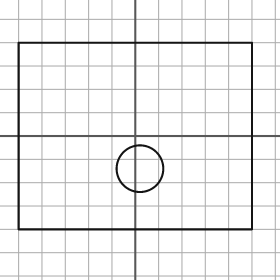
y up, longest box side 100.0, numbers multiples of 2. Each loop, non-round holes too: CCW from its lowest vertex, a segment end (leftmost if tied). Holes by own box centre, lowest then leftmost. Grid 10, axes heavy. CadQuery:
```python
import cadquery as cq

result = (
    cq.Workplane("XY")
    .moveTo(-50.0, -40.0)
    .lineTo(50.0, -40.0)
    .lineTo(50.0, 40.0)
    .lineTo(-50.0, 40.0)
    .close()
    .moveTo(2.0, -14.0)
    .circle(10.0)
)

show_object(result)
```